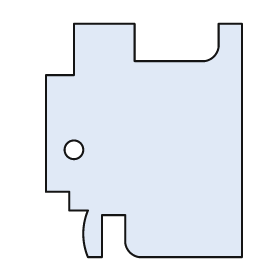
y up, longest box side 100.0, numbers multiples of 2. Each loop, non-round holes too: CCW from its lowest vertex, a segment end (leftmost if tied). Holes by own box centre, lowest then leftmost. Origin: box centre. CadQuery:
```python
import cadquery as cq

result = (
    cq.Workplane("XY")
    .moveTo(-24.0, -50.0)
    .lineTo(-18.0, -50.0)
    .lineTo(-18.0, -32.0)
    .lineTo(-8.0, -32.0)
    .lineTo(-8.0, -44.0)
    .threePointArc((-6.0, -48.0), (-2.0, -50.0))
    .lineTo(42.0, -50.0)
    .lineTo(42.0, 50.0)
    .lineTo(32.0, 50.0)
    .lineTo(32.0, 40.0)
    .threePointArc((30.0, 36.0), (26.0, 34.0))
    .lineTo(-4.0, 34.0)
    .lineTo(-4.0, 50.0)
    .lineTo(-30.0, 50.0)
    .lineTo(-30.0, 28.0)
    .lineTo(-42.0, 28.0)
    .lineTo(-42.0, -22.0)
    .lineTo(-32.0, -22.0)
    .lineTo(-32.0, -30.0)
    .lineTo(-24.0, -30.0)
    .threePointArc((-26.0, -40.0), (-24.0, -50.0))
    .close()
    .moveTo(-30.0, -4.0)
    .circle(4.0)
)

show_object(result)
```